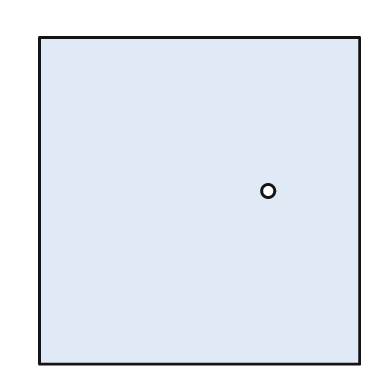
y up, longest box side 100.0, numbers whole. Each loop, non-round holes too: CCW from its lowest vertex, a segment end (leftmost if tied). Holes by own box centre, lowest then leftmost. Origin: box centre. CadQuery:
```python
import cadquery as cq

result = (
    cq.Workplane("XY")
    .moveTo(-49.0, -50.0)
    .lineTo(49.0, -50.0)
    .lineTo(49.0, 50.0)
    .lineTo(-49.0, 50.0)
    .close()
    .moveTo(21.0, 3.0)
    .circle(2.0)
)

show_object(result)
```